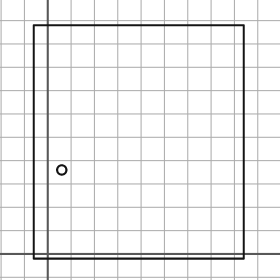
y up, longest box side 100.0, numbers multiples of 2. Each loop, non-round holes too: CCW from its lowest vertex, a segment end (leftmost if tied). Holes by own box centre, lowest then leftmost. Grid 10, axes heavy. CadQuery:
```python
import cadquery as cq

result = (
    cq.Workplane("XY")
    .moveTo(-6.0, -2.0)
    .lineTo(84.0, -2.0)
    .lineTo(84.0, 98.0)
    .lineTo(-6.0, 98.0)
    .close()
    .moveTo(6.0, 36.0)
    .circle(2.0)
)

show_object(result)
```